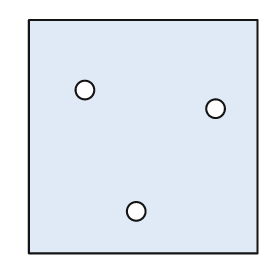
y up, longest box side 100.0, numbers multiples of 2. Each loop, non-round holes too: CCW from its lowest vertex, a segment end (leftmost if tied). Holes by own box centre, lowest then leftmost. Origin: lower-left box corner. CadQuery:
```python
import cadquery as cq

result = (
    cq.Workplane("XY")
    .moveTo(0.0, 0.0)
    .lineTo(98.0, 0.0)
    .lineTo(98.0, 100.0)
    .lineTo(0.0, 100.0)
    .close()
    .moveTo(46.0, 18.0)
    .circle(4.0)
    .moveTo(80.0, 62.0)
    .circle(4.0)
    .moveTo(24.0, 70.0)
    .circle(4.0)
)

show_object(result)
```